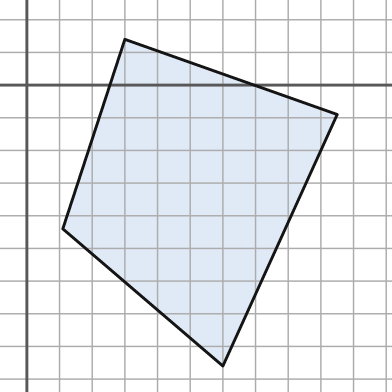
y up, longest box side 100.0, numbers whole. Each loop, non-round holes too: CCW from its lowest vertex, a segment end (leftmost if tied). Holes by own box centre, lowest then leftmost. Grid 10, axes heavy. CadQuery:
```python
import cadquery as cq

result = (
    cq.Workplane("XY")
    .moveTo(60.0, -86.0)
    .lineTo(95.0, -9.0)
    .lineTo(30.0, 14.0)
    .lineTo(11.0, -44.0)
    .close()
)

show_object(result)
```